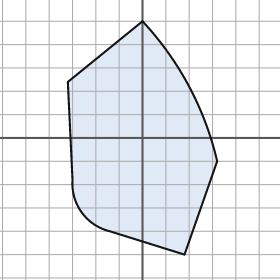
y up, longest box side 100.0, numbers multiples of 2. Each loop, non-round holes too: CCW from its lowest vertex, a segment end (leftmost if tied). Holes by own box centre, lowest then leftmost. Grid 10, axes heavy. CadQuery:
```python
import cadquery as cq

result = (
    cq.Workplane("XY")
    .moveTo(18.0, -50.0)
    .lineTo(32.0, -10.0)
    .threePointArc((20.0, 22.0), (0.0, 50.0))
    .lineTo(-32.0, 24.0)
    .lineTo(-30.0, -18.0)
    .threePointArc((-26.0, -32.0), (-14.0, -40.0))
    .close()
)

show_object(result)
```